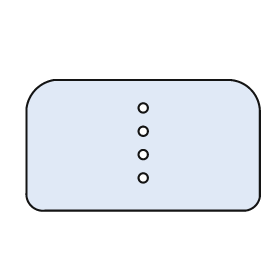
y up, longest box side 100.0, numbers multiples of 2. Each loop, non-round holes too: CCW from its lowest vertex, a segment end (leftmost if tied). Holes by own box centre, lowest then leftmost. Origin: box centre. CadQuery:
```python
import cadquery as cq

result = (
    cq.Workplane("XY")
    .moveTo(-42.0, -28.0)
    .lineTo(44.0, -28.0)
    .threePointArc((48.0, -26.0), (50.0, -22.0))
    .lineTo(50.0, 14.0)
    .threePointArc((46.0, 24.0), (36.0, 28.0))
    .lineTo(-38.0, 28.0)
    .threePointArc((-46.0, 24.0), (-50.0, 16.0))
    .lineTo(-50.0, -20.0)
    .threePointArc((-48.0, -26.0), (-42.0, -28.0))
    .close()
    .moveTo(0.0, -14.0)
    .circle(2.0)
    .moveTo(0.0, -4.0)
    .circle(2.0)
    .moveTo(0.0, 6.0)
    .circle(2.0)
    .moveTo(0.0, 16.0)
    .circle(2.0)
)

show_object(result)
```